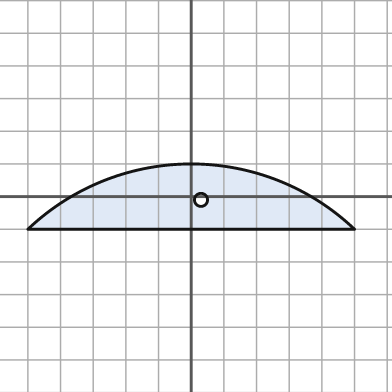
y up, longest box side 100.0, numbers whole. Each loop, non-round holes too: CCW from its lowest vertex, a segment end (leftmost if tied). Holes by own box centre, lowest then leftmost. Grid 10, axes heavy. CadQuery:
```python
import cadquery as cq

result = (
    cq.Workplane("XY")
    .moveTo(-50.0, -10.0)
    .lineTo(50.0, -10.0)
    .threePointArc((0.0, 10.0), (-50.0, -10.0))
    .close()
    .moveTo(3.0, -1.0)
    .circle(2.0)
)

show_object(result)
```